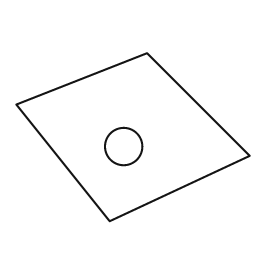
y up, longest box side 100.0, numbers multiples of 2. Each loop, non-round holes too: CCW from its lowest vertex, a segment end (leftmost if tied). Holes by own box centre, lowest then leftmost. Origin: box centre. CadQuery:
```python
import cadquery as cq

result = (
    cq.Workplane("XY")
    .moveTo(-10.0, -36.0)
    .lineTo(50.0, -8.0)
    .lineTo(6.0, 36.0)
    .lineTo(-50.0, 14.0)
    .close()
    .moveTo(-4.0, -4.0)
    .circle(8.0)
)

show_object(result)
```